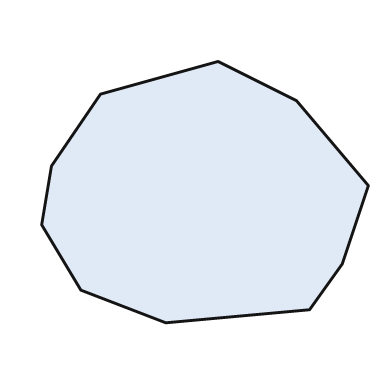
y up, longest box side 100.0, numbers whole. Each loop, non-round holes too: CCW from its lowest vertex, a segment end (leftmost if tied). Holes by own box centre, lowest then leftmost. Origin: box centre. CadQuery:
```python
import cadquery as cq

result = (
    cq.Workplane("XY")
    .moveTo(-12.0, -40.0)
    .lineTo(32.0, -36.0)
    .lineTo(42.0, -22.0)
    .lineTo(50.0, 2.0)
    .lineTo(28.0, 28.0)
    .lineTo(4.0, 40.0)
    .lineTo(-32.0, 30.0)
    .lineTo(-47.0, 8.0)
    .lineTo(-50.0, -10.0)
    .lineTo(-38.0, -30.0)
    .close()
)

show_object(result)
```